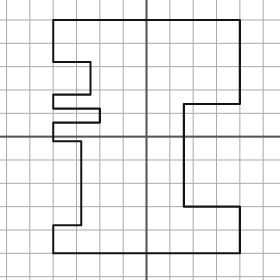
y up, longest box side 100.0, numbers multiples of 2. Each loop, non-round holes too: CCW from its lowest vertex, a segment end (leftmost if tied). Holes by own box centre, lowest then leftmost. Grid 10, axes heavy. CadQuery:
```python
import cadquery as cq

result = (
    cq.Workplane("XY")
    .moveTo(-40.0, -50.0)
    .lineTo(40.0, -50.0)
    .lineTo(40.0, -30.0)
    .lineTo(16.0, -30.0)
    .lineTo(16.0, 14.0)
    .lineTo(40.0, 14.0)
    .lineTo(40.0, 50.0)
    .lineTo(-40.0, 50.0)
    .lineTo(-40.0, 32.0)
    .lineTo(-24.0, 32.0)
    .lineTo(-24.0, 18.0)
    .lineTo(-40.0, 18.0)
    .lineTo(-40.0, 12.0)
    .lineTo(-20.0, 12.0)
    .lineTo(-20.0, 6.0)
    .lineTo(-40.0, 6.0)
    .lineTo(-40.0, -2.0)
    .lineTo(-28.0, -2.0)
    .lineTo(-28.0, -38.0)
    .lineTo(-40.0, -38.0)
    .close()
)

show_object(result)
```